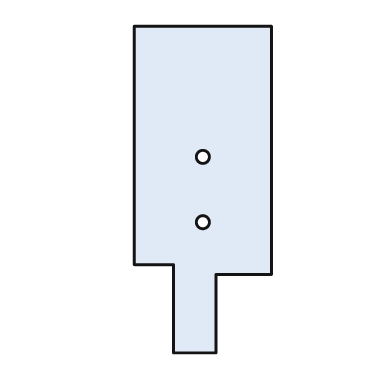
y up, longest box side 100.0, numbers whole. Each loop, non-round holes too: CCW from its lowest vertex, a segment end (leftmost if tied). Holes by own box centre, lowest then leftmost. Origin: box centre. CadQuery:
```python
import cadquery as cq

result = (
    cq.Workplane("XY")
    .moveTo(-9.0, -50.0)
    .lineTo(4.0, -50.0)
    .lineTo(4.0, -26.0)
    .lineTo(21.0, -26.0)
    .lineTo(21.0, 50.0)
    .lineTo(-21.0, 50.0)
    .lineTo(-21.0, -23.0)
    .lineTo(-9.0, -23.0)
    .close()
    .moveTo(0.0, -10.0)
    .circle(2.0)
    .moveTo(0.0, 10.0)
    .circle(2.0)
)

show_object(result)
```